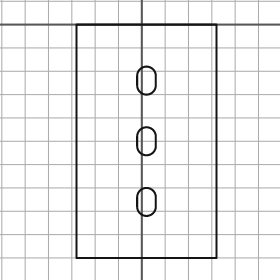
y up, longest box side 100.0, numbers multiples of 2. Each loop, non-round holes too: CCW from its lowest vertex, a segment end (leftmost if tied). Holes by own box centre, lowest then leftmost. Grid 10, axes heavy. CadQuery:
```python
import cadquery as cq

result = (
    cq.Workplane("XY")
    .moveTo(-28.0, -100.0)
    .lineTo(32.0, -100.0)
    .lineTo(32.0, 0.0)
    .lineTo(-28.0, 0.0)
    .close()
    .moveTo(-2.0, -78.0)
    .threePointArc((2.0, -82.0), (6.0, -78.0))
    .lineTo(6.0, -74.0)
    .threePointArc((2.0, -70.0), (-2.0, -74.0))
    .close()
    .moveTo(-2.0, -52.0)
    .threePointArc((2.0, -56.0), (6.0, -52.0))
    .lineTo(6.0, -48.0)
    .threePointArc((2.0, -44.0), (-2.0, -48.0))
    .close()
    .moveTo(-2.0, -26.0)
    .threePointArc((2.0, -30.0), (6.0, -26.0))
    .lineTo(6.0, -22.0)
    .threePointArc((2.0, -18.0), (-2.0, -22.0))
    .close()
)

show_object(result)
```